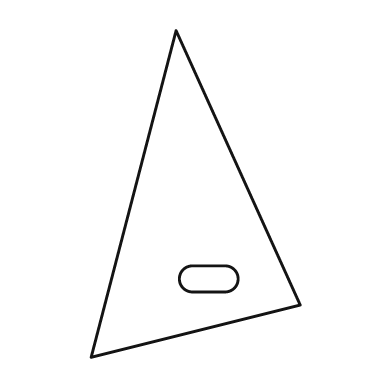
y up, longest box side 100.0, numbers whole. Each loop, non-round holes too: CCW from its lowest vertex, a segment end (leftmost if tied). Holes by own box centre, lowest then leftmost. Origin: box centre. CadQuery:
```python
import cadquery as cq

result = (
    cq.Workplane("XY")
    .moveTo(-32.0, -50.0)
    .lineTo(32.0, -34.0)
    .lineTo(-6.0, 50.0)
    .close()
    .moveTo(-1.0, -30.0)
    .lineTo(9.0, -30.0)
    .threePointArc((13.0, -26.0), (9.0, -22.0))
    .lineTo(-1.0, -22.0)
    .threePointArc((-5.0, -26.0), (-1.0, -30.0))
    .close()
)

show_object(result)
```